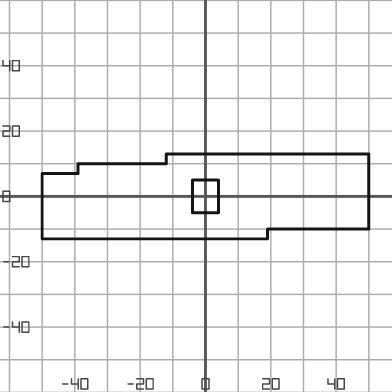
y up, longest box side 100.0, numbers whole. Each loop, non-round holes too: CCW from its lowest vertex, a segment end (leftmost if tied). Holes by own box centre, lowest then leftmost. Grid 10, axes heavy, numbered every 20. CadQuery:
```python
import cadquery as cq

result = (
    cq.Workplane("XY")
    .moveTo(-50.0, -13.0)
    .lineTo(19.0, -13.0)
    .lineTo(19.0, -10.0)
    .lineTo(50.0, -10.0)
    .lineTo(50.0, 13.0)
    .lineTo(-12.0, 13.0)
    .lineTo(-12.0, 10.0)
    .lineTo(-39.0, 10.0)
    .lineTo(-39.0, 7.0)
    .lineTo(-50.0, 7.0)
    .close()
    .moveTo(-4.0, -5.0)
    .lineTo(4.0, -5.0)
    .lineTo(4.0, 5.0)
    .lineTo(-4.0, 5.0)
    .close()
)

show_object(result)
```